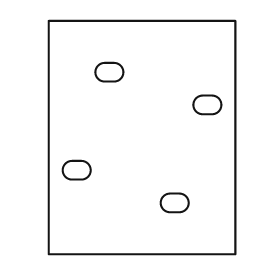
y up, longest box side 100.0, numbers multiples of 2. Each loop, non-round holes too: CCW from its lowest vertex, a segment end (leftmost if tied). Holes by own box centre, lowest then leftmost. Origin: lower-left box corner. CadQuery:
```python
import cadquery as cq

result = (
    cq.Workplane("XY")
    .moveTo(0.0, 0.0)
    .lineTo(80.0, 0.0)
    .lineTo(80.0, 100.0)
    .lineTo(0.0, 100.0)
    .close()
    .moveTo(52.0, 18.0)
    .lineTo(56.0, 18.0)
    .threePointArc((60.0, 22.0), (56.0, 26.0))
    .lineTo(52.0, 26.0)
    .threePointArc((48.0, 22.0), (52.0, 18.0))
    .close()
    .moveTo(10.0, 32.0)
    .lineTo(14.0, 32.0)
    .threePointArc((18.0, 36.0), (14.0, 40.0))
    .lineTo(10.0, 40.0)
    .threePointArc((6.0, 36.0), (10.0, 32.0))
    .close()
    .moveTo(66.0, 60.0)
    .lineTo(70.0, 60.0)
    .threePointArc((74.0, 64.0), (70.0, 68.0))
    .lineTo(66.0, 68.0)
    .threePointArc((62.0, 64.0), (66.0, 60.0))
    .close()
    .moveTo(24.0, 74.0)
    .lineTo(28.0, 74.0)
    .threePointArc((32.0, 78.0), (28.0, 82.0))
    .lineTo(24.0, 82.0)
    .threePointArc((20.0, 78.0), (24.0, 74.0))
    .close()
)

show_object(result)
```